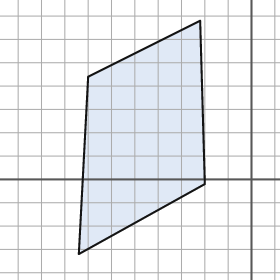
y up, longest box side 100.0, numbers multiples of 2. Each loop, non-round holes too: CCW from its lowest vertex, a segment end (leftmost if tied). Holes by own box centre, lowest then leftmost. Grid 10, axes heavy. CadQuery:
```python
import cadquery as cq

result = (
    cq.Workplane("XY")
    .moveTo(-74.0, -32.0)
    .lineTo(-20.0, -2.0)
    .lineTo(-22.0, 68.0)
    .lineTo(-70.0, 44.0)
    .close()
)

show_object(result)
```